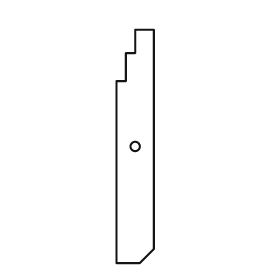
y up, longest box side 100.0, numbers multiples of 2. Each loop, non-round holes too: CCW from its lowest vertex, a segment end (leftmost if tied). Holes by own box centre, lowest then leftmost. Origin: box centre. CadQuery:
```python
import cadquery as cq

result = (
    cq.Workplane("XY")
    .moveTo(-8.0, -50.0)
    .lineTo(2.0, -50.0)
    .lineTo(8.0, -44.0)
    .lineTo(8.0, 50.0)
    .lineTo(0.0, 50.0)
    .lineTo(0.0, 40.0)
    .lineTo(-4.0, 40.0)
    .lineTo(-4.0, 28.0)
    .lineTo(-8.0, 28.0)
    .close()
    .moveTo(0.0, 0.0)
    .circle(2.0)
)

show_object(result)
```